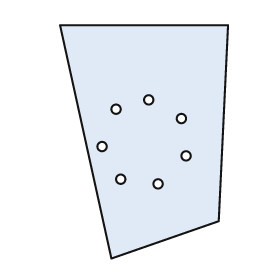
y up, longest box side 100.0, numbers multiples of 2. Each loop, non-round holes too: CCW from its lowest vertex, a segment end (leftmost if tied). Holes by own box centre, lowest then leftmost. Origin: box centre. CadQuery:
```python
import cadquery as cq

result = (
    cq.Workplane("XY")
    .moveTo(-14.0, -50.0)
    .lineTo(32.0, -34.0)
    .lineTo(36.0, 50.0)
    .lineTo(-36.0, 50.0)
    .close()
    .moveTo(6.0, -18.0)
    .circle(2.0)
    .moveTo(-10.0, -16.0)
    .circle(2.0)
    .moveTo(18.0, -6.0)
    .circle(2.0)
    .moveTo(-18.0, -2.0)
    .circle(2.0)
    .moveTo(16.0, 10.0)
    .circle(2.0)
    .moveTo(-12.0, 14.0)
    .circle(2.0)
    .moveTo(2.0, 18.0)
    .circle(2.0)
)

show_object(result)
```